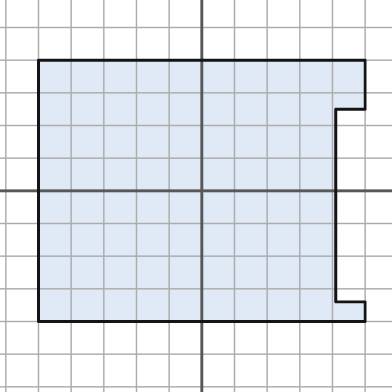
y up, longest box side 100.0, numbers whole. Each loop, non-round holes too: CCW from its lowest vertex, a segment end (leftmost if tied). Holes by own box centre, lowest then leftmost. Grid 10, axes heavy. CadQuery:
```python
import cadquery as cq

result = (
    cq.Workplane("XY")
    .moveTo(-50.0, -40.0)
    .lineTo(50.0, -40.0)
    .lineTo(50.0, -34.0)
    .lineTo(41.0, -34.0)
    .lineTo(41.0, 25.0)
    .lineTo(50.0, 25.0)
    .lineTo(50.0, 40.0)
    .lineTo(-50.0, 40.0)
    .close()
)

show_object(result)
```